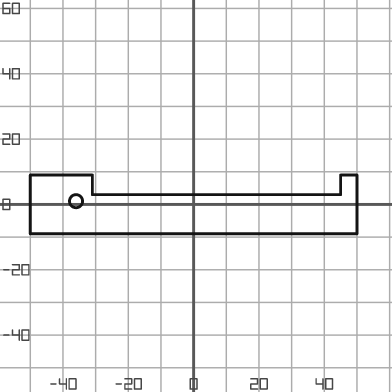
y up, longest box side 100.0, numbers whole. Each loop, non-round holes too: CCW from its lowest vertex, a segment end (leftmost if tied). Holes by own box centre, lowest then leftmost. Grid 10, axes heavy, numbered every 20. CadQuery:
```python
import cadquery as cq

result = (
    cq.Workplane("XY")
    .moveTo(-50.0, -9.0)
    .lineTo(50.0, -9.0)
    .lineTo(50.0, 9.0)
    .lineTo(45.0, 9.0)
    .lineTo(45.0, 3.0)
    .lineTo(-31.0, 3.0)
    .lineTo(-31.0, 9.0)
    .lineTo(-50.0, 9.0)
    .close()
    .moveTo(-36.0, 1.0)
    .circle(2.0)
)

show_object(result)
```